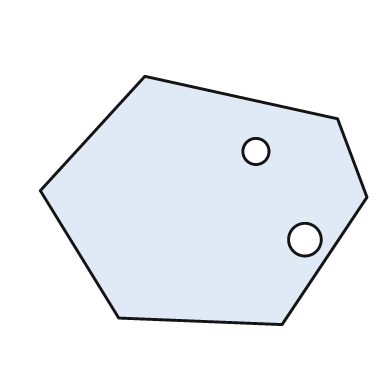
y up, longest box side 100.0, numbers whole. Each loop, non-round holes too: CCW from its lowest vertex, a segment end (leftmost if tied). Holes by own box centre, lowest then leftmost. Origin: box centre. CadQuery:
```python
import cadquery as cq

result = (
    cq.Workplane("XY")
    .moveTo(24.0, -38.0)
    .lineTo(50.0, 1.0)
    .lineTo(41.0, 25.0)
    .lineTo(-18.0, 38.0)
    .lineTo(-50.0, 3.0)
    .lineTo(-26.0, -36.0)
    .close()
    .moveTo(31.0, -12.0)
    .circle(5.0)
    .moveTo(16.0, 15.0)
    .circle(4.0)
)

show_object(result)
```